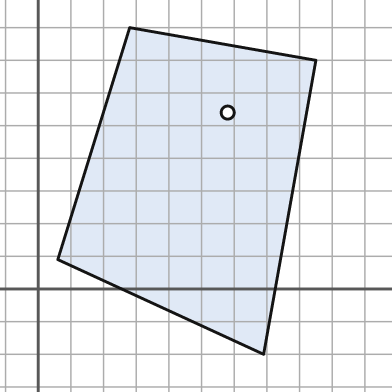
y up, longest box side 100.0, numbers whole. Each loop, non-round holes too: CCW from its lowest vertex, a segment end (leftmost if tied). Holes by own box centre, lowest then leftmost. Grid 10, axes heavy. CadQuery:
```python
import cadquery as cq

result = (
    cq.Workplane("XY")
    .moveTo(69.0, -20.0)
    .lineTo(85.0, 70.0)
    .lineTo(28.0, 80.0)
    .lineTo(6.0, 9.0)
    .close()
    .moveTo(58.0, 54.0)
    .circle(2.0)
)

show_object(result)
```